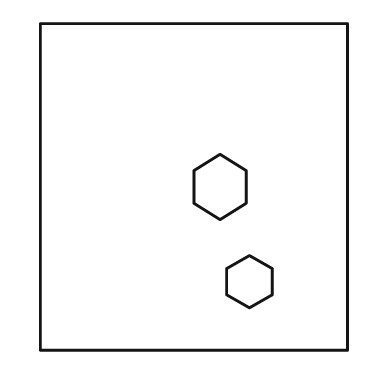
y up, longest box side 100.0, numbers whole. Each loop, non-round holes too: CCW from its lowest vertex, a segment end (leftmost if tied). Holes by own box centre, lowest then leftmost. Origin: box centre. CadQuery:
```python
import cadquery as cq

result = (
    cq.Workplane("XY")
    .moveTo(-47.0, -50.0)
    .lineTo(47.0, -50.0)
    .lineTo(47.0, 50.0)
    .lineTo(-47.0, 50.0)
    .close()
    .moveTo(17.0, -37.0)
    .lineTo(24.0, -33.0)
    .lineTo(24.0, -25.0)
    .lineTo(17.0, -21.0)
    .lineTo(10.0, -25.0)
    .lineTo(10.0, -33.0)
    .close()
    .moveTo(8.0, -10.0)
    .lineTo(16.0, -5.0)
    .lineTo(16.0, 5.0)
    .lineTo(8.0, 10.0)
    .lineTo(0.0, 5.0)
    .lineTo(0.0, -5.0)
    .close()
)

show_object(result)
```